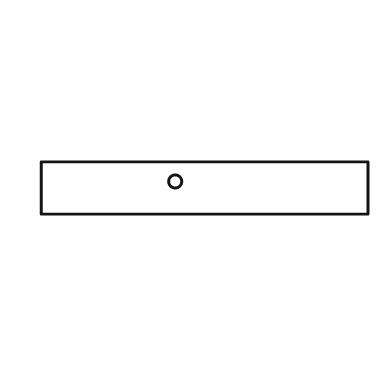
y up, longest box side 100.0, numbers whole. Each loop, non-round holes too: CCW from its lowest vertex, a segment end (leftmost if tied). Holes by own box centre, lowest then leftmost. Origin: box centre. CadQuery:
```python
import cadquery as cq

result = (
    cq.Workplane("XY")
    .moveTo(-50.0, -8.0)
    .lineTo(50.0, -8.0)
    .lineTo(50.0, 8.0)
    .lineTo(-50.0, 8.0)
    .close()
    .moveTo(-9.0, 2.0)
    .circle(2.0)
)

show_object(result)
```